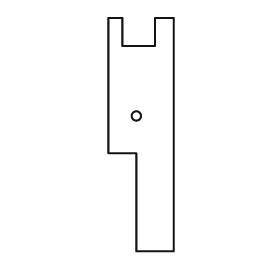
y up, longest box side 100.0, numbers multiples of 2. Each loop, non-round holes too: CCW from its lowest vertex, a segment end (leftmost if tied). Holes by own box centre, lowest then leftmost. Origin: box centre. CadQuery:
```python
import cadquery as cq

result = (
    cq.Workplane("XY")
    .moveTo(-2.0, -50.0)
    .lineTo(14.0, -50.0)
    .lineTo(14.0, 50.0)
    .lineTo(6.0, 50.0)
    .lineTo(6.0, 38.0)
    .lineTo(-8.0, 38.0)
    .lineTo(-8.0, 50.0)
    .lineTo(-14.0, 50.0)
    .lineTo(-14.0, -8.0)
    .lineTo(-2.0, -8.0)
    .close()
    .moveTo(-2.0, 8.0)
    .circle(2.0)
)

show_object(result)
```